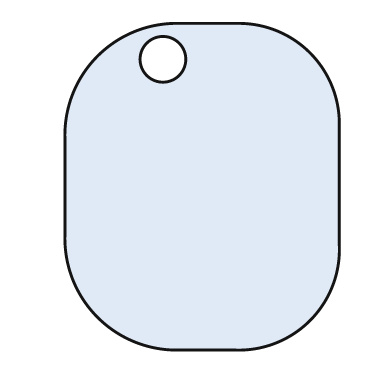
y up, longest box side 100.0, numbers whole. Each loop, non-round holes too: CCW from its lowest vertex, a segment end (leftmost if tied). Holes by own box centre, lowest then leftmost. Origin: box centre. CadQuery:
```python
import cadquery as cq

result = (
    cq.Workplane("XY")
    .moveTo(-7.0, -50.0)
    .lineTo(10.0, -50.0)
    .threePointArc((33.0, -41.0), (42.0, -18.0))
    .lineTo(42.0, 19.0)
    .threePointArc((33.0, 41.0), (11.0, 50.0))
    .lineTo(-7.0, 50.0)
    .threePointArc((-32.0, 40.0), (-42.0, 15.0))
    .lineTo(-42.0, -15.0)
    .threePointArc((-32.0, -40.0), (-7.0, -50.0))
    .close()
    .moveTo(-12.0, 39.0)
    .circle(7.0)
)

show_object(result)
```